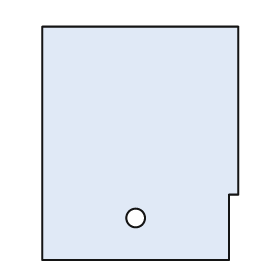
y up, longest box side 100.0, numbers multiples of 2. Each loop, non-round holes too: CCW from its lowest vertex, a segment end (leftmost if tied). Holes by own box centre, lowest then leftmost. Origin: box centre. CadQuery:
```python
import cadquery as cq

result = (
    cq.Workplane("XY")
    .moveTo(-42.0, -50.0)
    .lineTo(38.0, -50.0)
    .lineTo(38.0, -22.0)
    .lineTo(42.0, -22.0)
    .lineTo(42.0, 50.0)
    .lineTo(-42.0, 50.0)
    .close()
    .moveTo(-2.0, -32.0)
    .circle(4.0)
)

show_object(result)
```